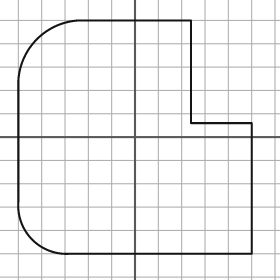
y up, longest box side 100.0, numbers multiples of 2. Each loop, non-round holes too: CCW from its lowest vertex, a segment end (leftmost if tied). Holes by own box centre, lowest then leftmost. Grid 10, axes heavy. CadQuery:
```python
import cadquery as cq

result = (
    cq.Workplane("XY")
    .moveTo(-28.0, -50.0)
    .lineTo(50.0, -50.0)
    .lineTo(50.0, 6.0)
    .lineTo(24.0, 6.0)
    .lineTo(24.0, 50.0)
    .lineTo(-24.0, 50.0)
    .threePointArc((-42.0, 42.0), (-50.0, 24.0))
    .lineTo(-50.0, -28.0)
    .threePointArc((-44.0, -44.0), (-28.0, -50.0))
    .close()
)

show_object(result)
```